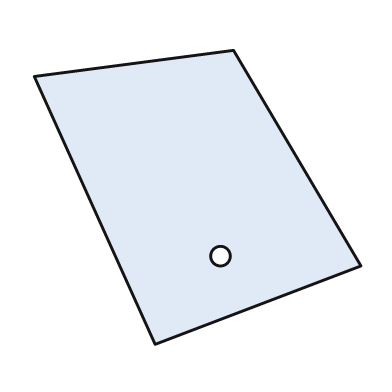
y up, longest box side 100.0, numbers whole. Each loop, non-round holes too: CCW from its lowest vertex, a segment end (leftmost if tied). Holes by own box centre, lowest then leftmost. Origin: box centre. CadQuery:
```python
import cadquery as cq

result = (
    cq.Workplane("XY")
    .moveTo(-13.0, -45.0)
    .lineTo(50.0, -21.0)
    .lineTo(11.0, 45.0)
    .lineTo(-50.0, 37.0)
    .close()
    .moveTo(7.0, -18.0)
    .circle(3.0)
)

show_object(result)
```